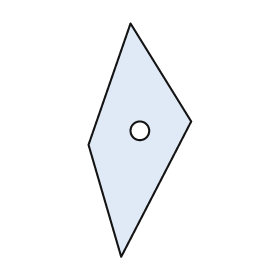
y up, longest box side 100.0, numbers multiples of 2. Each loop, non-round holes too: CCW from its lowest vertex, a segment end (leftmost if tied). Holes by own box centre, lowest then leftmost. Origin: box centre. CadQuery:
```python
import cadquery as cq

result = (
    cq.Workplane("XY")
    .moveTo(-8.0, -50.0)
    .lineTo(22.0, 8.0)
    .lineTo(-4.0, 50.0)
    .lineTo(-22.0, -2.0)
    .close()
    .moveTo(0.0, 4.0)
    .circle(4.0)
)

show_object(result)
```